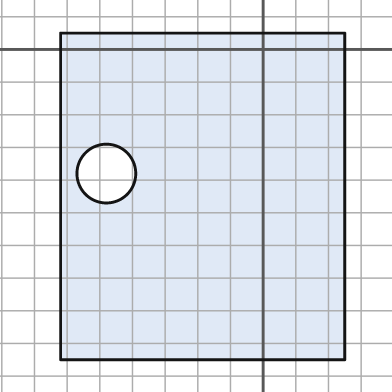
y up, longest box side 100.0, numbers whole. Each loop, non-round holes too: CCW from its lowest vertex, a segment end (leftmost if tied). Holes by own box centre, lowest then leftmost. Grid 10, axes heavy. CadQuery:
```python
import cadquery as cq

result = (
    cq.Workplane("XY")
    .moveTo(-62.0, -95.0)
    .lineTo(25.0, -95.0)
    .lineTo(25.0, 5.0)
    .lineTo(-62.0, 5.0)
    .close()
    .moveTo(-48.0, -38.0)
    .circle(9.0)
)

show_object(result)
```